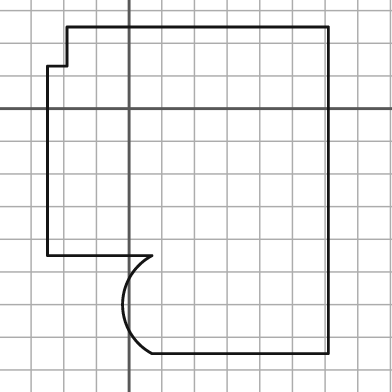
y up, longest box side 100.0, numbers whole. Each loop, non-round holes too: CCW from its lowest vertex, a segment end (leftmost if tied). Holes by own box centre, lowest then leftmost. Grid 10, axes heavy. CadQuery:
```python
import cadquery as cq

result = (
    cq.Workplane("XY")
    .moveTo(7.0, -75.0)
    .lineTo(61.0, -75.0)
    .lineTo(61.0, 25.0)
    .lineTo(-19.0, 25.0)
    .lineTo(-19.0, 13.0)
    .lineTo(-25.0, 13.0)
    .lineTo(-25.0, -45.0)
    .lineTo(7.0, -45.0)
    .threePointArc((-2.0, -60.0), (7.0, -75.0))
    .close()
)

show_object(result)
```